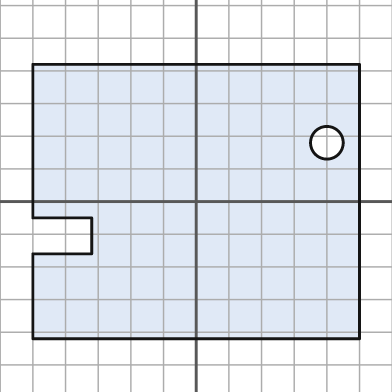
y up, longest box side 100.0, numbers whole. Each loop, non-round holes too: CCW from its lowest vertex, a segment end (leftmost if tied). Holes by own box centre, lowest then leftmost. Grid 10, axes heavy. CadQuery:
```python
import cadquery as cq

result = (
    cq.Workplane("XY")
    .moveTo(-50.0, -42.0)
    .lineTo(50.0, -42.0)
    .lineTo(50.0, 42.0)
    .lineTo(-50.0, 42.0)
    .lineTo(-50.0, -5.0)
    .lineTo(-32.0, -5.0)
    .lineTo(-32.0, -16.0)
    .lineTo(-50.0, -16.0)
    .close()
    .moveTo(40.0, 18.0)
    .circle(5.0)
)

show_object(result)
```